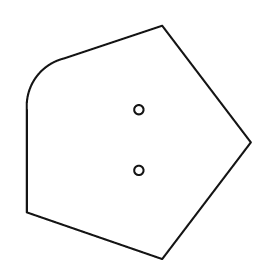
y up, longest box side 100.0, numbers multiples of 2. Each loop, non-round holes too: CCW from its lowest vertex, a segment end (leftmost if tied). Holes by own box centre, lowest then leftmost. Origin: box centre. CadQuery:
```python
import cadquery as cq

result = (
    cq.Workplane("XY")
    .moveTo(10.0, -50.0)
    .lineTo(48.0, 0.0)
    .lineTo(10.0, 50.0)
    .lineTo(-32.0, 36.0)
    .threePointArc((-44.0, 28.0), (-48.0, 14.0))
    .lineTo(-48.0, -30.0)
    .close()
    .moveTo(0.0, -12.0)
    .circle(2.0)
    .moveTo(0.0, 14.0)
    .circle(2.0)
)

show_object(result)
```